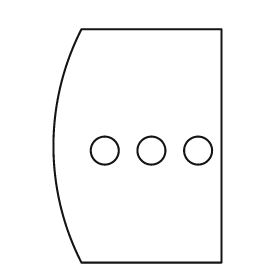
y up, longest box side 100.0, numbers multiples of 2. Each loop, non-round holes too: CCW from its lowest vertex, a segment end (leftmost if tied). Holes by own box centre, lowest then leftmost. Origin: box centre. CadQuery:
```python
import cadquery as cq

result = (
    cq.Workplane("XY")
    .moveTo(-24.0, -50.0)
    .lineTo(36.0, -50.0)
    .lineTo(36.0, 50.0)
    .lineTo(-24.0, 50.0)
    .threePointArc((-36.0, 0.0), (-24.0, -50.0))
    .close()
    .moveTo(-14.0, -2.0)
    .circle(6.0)
    .moveTo(6.0, -2.0)
    .circle(6.0)
    .moveTo(26.0, -2.0)
    .circle(6.0)
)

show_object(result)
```